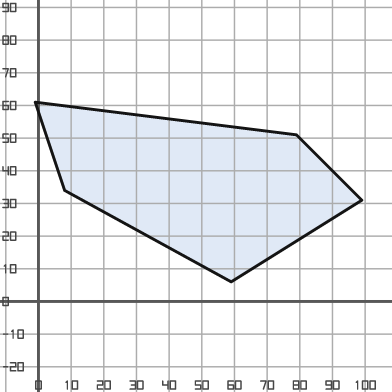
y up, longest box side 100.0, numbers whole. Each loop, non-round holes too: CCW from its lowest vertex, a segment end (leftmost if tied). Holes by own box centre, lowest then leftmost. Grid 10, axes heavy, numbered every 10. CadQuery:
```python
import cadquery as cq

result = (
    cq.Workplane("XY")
    .moveTo(59.0, 6.0)
    .lineTo(99.0, 31.0)
    .lineTo(79.0, 51.0)
    .lineTo(-1.0, 61.0)
    .lineTo(8.0, 34.0)
    .close()
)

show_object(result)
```